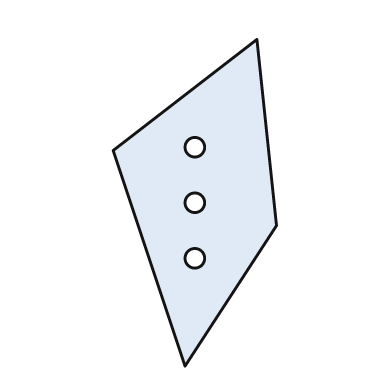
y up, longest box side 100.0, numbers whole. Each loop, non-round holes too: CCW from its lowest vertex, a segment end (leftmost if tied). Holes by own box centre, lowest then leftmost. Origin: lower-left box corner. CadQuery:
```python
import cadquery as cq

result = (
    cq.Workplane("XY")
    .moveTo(22.0, 0.0)
    .lineTo(50.0, 43.0)
    .lineTo(44.0, 100.0)
    .lineTo(0.0, 66.0)
    .close()
    .moveTo(25.0, 33.0)
    .circle(3.0)
    .moveTo(25.0, 50.0)
    .circle(3.0)
    .moveTo(25.0, 67.0)
    .circle(3.0)
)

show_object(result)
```